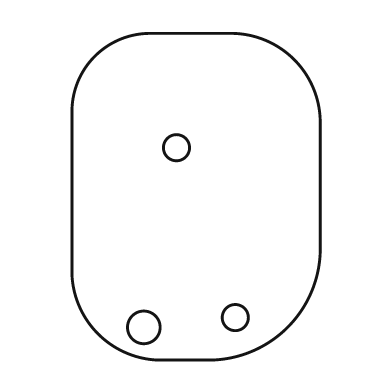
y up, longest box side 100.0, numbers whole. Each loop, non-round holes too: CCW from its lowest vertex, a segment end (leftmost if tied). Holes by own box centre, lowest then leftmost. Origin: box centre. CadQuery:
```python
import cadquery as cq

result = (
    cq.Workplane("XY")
    .moveTo(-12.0, -50.0)
    .lineTo(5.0, -50.0)
    .threePointArc((28.0, -40.0), (38.0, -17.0))
    .lineTo(38.0, 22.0)
    .threePointArc((30.0, 42.0), (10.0, 50.0))
    .lineTo(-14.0, 50.0)
    .threePointArc((-31.0, 43.0), (-38.0, 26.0))
    .lineTo(-38.0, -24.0)
    .threePointArc((-30.0, -42.0), (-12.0, -50.0))
    .close()
    .moveTo(-16.0, -40.0)
    .circle(5.0)
    .moveTo(12.0, -37.0)
    .circle(4.0)
    .moveTo(-6.0, 15.0)
    .circle(4.0)
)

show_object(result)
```